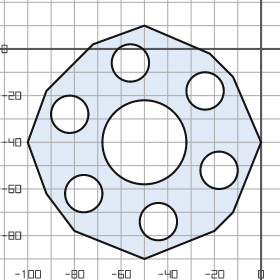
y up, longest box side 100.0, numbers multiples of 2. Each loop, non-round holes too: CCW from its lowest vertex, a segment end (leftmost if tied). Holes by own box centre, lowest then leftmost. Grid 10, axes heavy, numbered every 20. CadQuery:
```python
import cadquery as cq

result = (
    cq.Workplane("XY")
    .moveTo(-50.0, -90.0)
    .lineTo(-20.0, -78.0)
    .lineTo(-12.0, -70.0)
    .lineTo(0.0, -40.0)
    .lineTo(-12.0, -12.0)
    .lineTo(-22.0, -2.0)
    .lineTo(-50.0, 10.0)
    .lineTo(-72.0, 2.0)
    .lineTo(-92.0, -18.0)
    .lineTo(-100.0, -40.0)
    .lineTo(-92.0, -62.0)
    .lineTo(-80.0, -78.0)
    .close()
    .moveTo(-44.0, -74.0)
    .circle(8.0)
    .moveTo(-76.0, -62.0)
    .circle(8.0)
    .moveTo(-18.0, -52.0)
    .circle(8.0)
    .moveTo(-50.0, -40.0)
    .circle(18.0)
    .moveTo(-82.0, -28.0)
    .circle(8.0)
    .moveTo(-24.0, -18.0)
    .circle(8.0)
    .moveTo(-56.0, -6.0)
    .circle(8.0)
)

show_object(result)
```